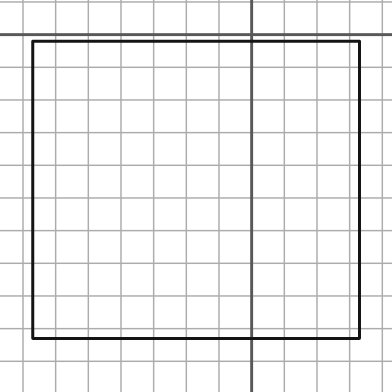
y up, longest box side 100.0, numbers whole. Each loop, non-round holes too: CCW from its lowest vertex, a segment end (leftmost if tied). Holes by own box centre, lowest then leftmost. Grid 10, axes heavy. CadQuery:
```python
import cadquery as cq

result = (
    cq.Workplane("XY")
    .moveTo(-67.0, -93.0)
    .lineTo(33.0, -93.0)
    .lineTo(33.0, -2.0)
    .lineTo(-67.0, -2.0)
    .close()
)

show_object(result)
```